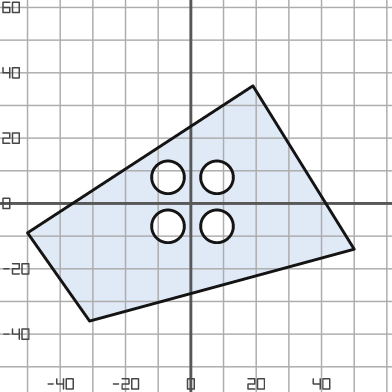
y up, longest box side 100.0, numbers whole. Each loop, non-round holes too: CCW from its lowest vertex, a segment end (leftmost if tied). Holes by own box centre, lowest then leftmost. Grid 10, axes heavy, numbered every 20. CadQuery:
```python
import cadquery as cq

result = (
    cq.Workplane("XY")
    .moveTo(-31.0, -36.0)
    .lineTo(50.0, -14.0)
    .lineTo(19.0, 36.0)
    .lineTo(-50.0, -9.0)
    .close()
    .moveTo(-7.0, -7.0)
    .circle(5.0)
    .moveTo(8.0, -7.0)
    .circle(5.0)
    .moveTo(-7.0, 8.0)
    .circle(5.0)
    .moveTo(8.0, 8.0)
    .circle(5.0)
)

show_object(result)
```